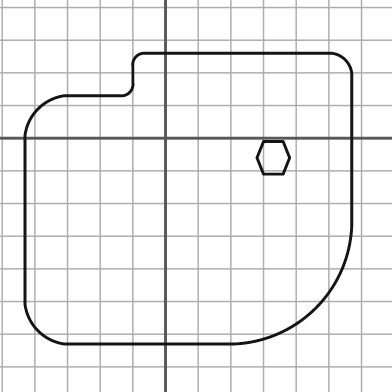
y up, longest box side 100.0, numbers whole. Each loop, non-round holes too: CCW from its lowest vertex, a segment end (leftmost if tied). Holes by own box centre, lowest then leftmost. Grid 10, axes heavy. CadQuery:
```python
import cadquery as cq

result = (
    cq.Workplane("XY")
    .moveTo(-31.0, -63.0)
    .lineTo(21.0, -63.0)
    .threePointArc((46.0, -52.0), (57.0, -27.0))
    .lineTo(57.0, 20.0)
    .threePointArc((55.0, 24.0), (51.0, 26.0))
    .lineTo(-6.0, 26.0)
    .threePointArc((-9.0, 25.0), (-10.0, 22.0))
    .lineTo(-10.0, 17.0)
    .threePointArc((-11.0, 14.0), (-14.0, 13.0))
    .lineTo(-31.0, 13.0)
    .threePointArc((-39.0, 9.0), (-43.0, 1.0))
    .lineTo(-43.0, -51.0)
    .threePointArc((-39.0, -59.0), (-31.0, -63.0))
    .close()
    .moveTo(30.0, -11.0)
    .lineTo(36.0, -11.0)
    .lineTo(38.0, -6.0)
    .lineTo(36.0, -1.0)
    .lineTo(30.0, -1.0)
    .lineTo(28.0, -6.0)
    .close()
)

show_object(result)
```